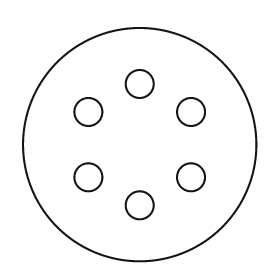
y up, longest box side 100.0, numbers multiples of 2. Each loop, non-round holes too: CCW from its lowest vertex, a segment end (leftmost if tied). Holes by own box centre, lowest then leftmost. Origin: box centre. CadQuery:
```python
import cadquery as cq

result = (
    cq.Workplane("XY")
    .moveTo(0.0, 0.0)
    .circle(50.0)
    .moveTo(0.0, -26.0)
    .circle(6.0)
    .moveTo(-22.0, -14.0)
    .circle(6.0)
    .moveTo(22.0, -14.0)
    .circle(6.0)
    .moveTo(-22.0, 14.0)
    .circle(6.0)
    .moveTo(22.0, 14.0)
    .circle(6.0)
    .moveTo(0.0, 26.0)
    .circle(6.0)
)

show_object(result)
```